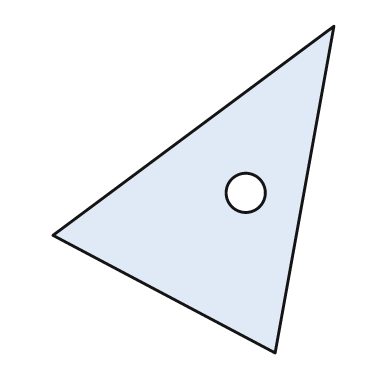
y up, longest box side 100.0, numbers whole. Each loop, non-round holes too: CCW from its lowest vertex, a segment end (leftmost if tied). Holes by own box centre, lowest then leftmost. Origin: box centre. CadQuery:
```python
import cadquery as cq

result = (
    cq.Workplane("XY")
    .moveTo(25.0, -50.0)
    .lineTo(43.0, 50.0)
    .lineTo(-43.0, -14.0)
    .close()
    .moveTo(16.0, -1.0)
    .circle(6.0)
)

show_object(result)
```